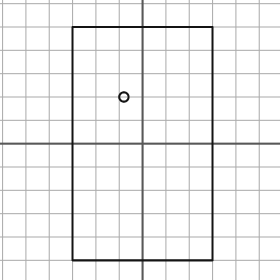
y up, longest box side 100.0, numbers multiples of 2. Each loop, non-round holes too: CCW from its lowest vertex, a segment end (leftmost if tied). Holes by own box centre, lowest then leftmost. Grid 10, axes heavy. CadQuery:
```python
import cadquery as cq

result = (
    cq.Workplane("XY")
    .moveTo(-30.0, -50.0)
    .lineTo(30.0, -50.0)
    .lineTo(30.0, 50.0)
    .lineTo(-30.0, 50.0)
    .close()
    .moveTo(-8.0, 20.0)
    .circle(2.0)
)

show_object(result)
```